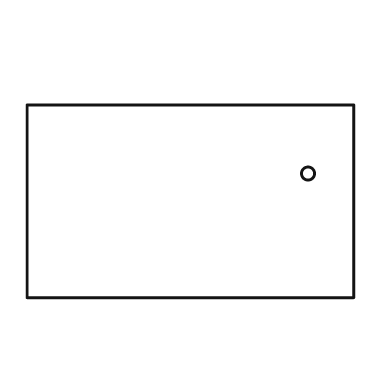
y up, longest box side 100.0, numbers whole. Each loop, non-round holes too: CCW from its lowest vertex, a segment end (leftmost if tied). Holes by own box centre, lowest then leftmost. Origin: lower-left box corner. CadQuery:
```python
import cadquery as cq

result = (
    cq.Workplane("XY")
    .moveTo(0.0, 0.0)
    .lineTo(100.0, 0.0)
    .lineTo(100.0, 59.0)
    .lineTo(0.0, 59.0)
    .close()
    .moveTo(86.0, 38.0)
    .circle(2.0)
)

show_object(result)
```